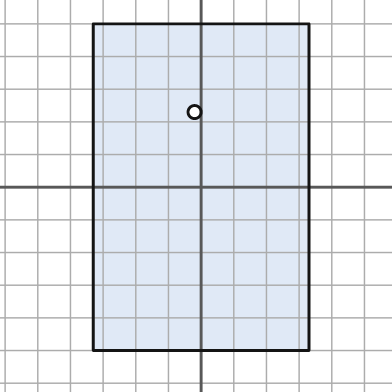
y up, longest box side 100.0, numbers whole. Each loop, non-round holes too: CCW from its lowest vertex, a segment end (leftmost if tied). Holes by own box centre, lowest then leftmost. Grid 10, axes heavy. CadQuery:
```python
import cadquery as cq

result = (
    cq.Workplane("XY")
    .moveTo(-33.0, -50.0)
    .lineTo(33.0, -50.0)
    .lineTo(33.0, 50.0)
    .lineTo(-33.0, 50.0)
    .close()
    .moveTo(-2.0, 23.0)
    .circle(2.0)
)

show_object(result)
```